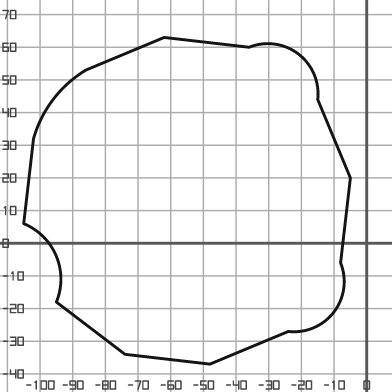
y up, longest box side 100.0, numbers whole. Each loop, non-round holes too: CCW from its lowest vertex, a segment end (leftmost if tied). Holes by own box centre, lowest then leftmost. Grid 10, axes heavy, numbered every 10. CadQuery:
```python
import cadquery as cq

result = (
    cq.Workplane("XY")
    .moveTo(-48.0, -37.0)
    .lineTo(-24.0, -27.0)
    .threePointArc((-10.0, -21.0), (-8.0, -6.0))
    .lineTo(-5.0, 20.0)
    .lineTo(-15.0, 44.0)
    .threePointArc((-21.0, 58.0), (-36.0, 60.0))
    .lineTo(-62.0, 63.0)
    .lineTo(-86.0, 53.0)
    .threePointArc((-96.0, 44.0), (-102.0, 32.0))
    .lineTo(-105.0, 6.0)
    .threePointArc((-95.0, -4.0), (-95.0, -18.0))
    .lineTo(-74.0, -34.0)
    .close()
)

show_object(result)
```